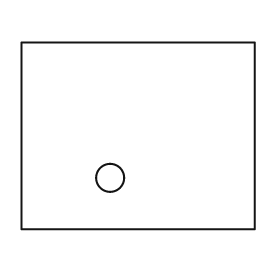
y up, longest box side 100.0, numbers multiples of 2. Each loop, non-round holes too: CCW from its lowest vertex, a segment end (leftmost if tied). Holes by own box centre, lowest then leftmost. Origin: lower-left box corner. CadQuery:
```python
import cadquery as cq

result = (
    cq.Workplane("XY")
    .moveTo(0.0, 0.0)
    .lineTo(100.0, 0.0)
    .lineTo(100.0, 80.0)
    .lineTo(0.0, 80.0)
    .close()
    .moveTo(38.0, 22.0)
    .circle(6.0)
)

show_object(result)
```